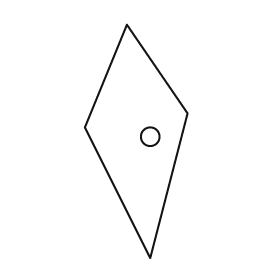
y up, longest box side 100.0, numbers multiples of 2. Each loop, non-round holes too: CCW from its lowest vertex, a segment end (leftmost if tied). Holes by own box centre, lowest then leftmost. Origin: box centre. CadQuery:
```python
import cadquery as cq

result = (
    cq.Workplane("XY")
    .moveTo(6.0, -50.0)
    .lineTo(22.0, 12.0)
    .lineTo(-4.0, 50.0)
    .lineTo(-22.0, 6.0)
    .close()
    .moveTo(6.0, 2.0)
    .circle(4.0)
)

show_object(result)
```